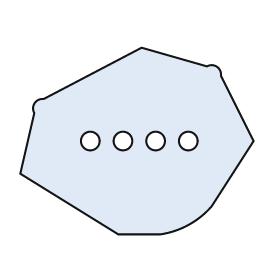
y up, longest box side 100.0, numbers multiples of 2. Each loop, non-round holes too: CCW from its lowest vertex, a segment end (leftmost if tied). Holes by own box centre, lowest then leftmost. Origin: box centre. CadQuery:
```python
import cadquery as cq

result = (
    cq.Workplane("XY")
    .moveTo(-8.0, -40.0)
    .lineTo(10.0, -40.0)
    .threePointArc((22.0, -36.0), (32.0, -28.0))
    .lineTo(50.0, 0.0)
    .lineTo(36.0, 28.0)
    .threePointArc((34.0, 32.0), (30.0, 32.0))
    .lineTo(2.0, 40.0)
    .lineTo(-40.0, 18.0)
    .threePointArc((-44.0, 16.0), (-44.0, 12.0))
    .lineTo(-50.0, -14.0)
    .close()
    .moveTo(-20.0, 0.0)
    .circle(4.0)
    .moveTo(-6.0, 0.0)
    .circle(4.0)
    .moveTo(8.0, 0.0)
    .circle(4.0)
    .moveTo(22.0, 0.0)
    .circle(4.0)
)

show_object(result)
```